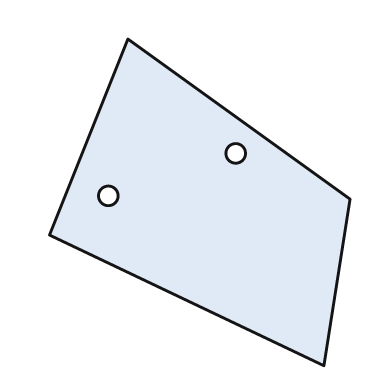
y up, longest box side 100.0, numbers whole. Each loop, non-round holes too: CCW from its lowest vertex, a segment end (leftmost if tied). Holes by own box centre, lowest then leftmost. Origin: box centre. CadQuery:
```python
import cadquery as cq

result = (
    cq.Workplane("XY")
    .moveTo(38.0, -50.0)
    .lineTo(46.0, 1.0)
    .lineTo(-22.0, 50.0)
    .lineTo(-46.0, -10.0)
    .close()
    .moveTo(-28.0, 2.0)
    .circle(3.0)
    .moveTo(11.0, 15.0)
    .circle(3.0)
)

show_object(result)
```